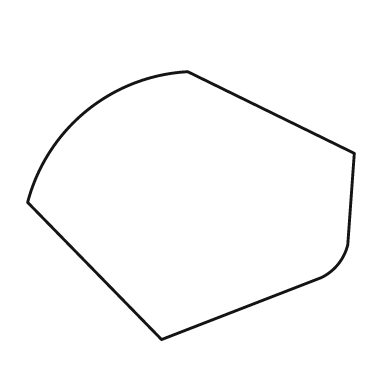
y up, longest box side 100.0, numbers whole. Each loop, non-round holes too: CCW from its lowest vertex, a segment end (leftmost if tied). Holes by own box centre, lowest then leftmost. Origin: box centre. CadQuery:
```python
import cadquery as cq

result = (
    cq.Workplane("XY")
    .moveTo(-9.0, -41.0)
    .lineTo(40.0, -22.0)
    .threePointArc((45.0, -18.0), (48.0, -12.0))
    .lineTo(50.0, 16.0)
    .lineTo(-1.0, 41.0)
    .threePointArc((-32.0, 29.0), (-50.0, 1.0))
    .close()
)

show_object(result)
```